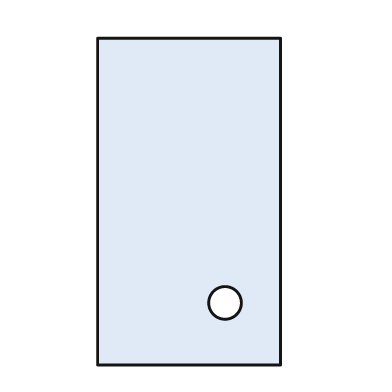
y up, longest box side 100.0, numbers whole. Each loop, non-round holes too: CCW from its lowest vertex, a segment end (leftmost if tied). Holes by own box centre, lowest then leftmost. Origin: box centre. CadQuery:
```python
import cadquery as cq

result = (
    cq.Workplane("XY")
    .moveTo(-28.0, -50.0)
    .lineTo(28.0, -50.0)
    .lineTo(28.0, 50.0)
    .lineTo(-28.0, 50.0)
    .close()
    .moveTo(11.0, -31.0)
    .circle(5.0)
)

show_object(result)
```